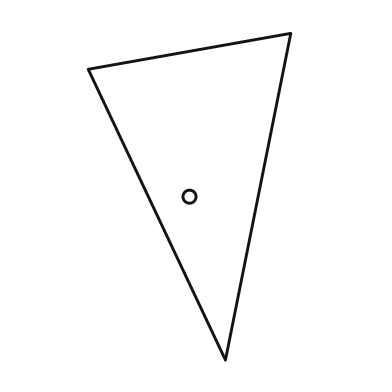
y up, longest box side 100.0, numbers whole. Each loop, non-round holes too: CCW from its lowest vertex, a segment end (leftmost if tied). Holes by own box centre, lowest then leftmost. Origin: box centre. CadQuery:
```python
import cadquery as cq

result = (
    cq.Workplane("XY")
    .moveTo(11.0, -50.0)
    .lineTo(31.0, 50.0)
    .lineTo(-31.0, 39.0)
    .close()
    .moveTo(0.0, 0.0)
    .circle(2.0)
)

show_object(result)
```